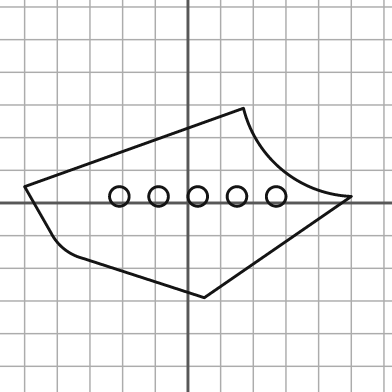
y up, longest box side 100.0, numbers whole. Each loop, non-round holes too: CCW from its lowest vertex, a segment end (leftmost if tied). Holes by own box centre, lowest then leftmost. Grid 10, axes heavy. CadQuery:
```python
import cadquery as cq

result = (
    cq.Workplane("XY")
    .moveTo(5.0, -29.0)
    .lineTo(50.0, 2.0)
    .threePointArc((29.0, 10.0), (17.0, 29.0))
    .lineTo(-50.0, 5.0)
    .lineTo(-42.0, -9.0)
    .threePointArc((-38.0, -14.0), (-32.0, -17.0))
    .close()
    .moveTo(-21.0, 2.0)
    .circle(3.0)
    .moveTo(-9.0, 2.0)
    .circle(3.0)
    .moveTo(3.0, 2.0)
    .circle(3.0)
    .moveTo(15.0, 2.0)
    .circle(3.0)
    .moveTo(27.0, 2.0)
    .circle(3.0)
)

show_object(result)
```